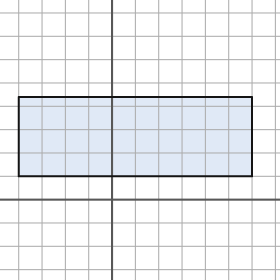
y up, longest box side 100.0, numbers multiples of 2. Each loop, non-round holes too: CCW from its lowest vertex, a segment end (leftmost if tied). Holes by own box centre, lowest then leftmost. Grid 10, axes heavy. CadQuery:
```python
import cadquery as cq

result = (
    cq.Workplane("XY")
    .moveTo(-40.0, 10.0)
    .lineTo(60.0, 10.0)
    .lineTo(60.0, 44.0)
    .lineTo(-40.0, 44.0)
    .close()
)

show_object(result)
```